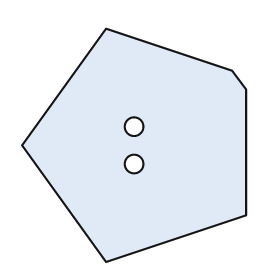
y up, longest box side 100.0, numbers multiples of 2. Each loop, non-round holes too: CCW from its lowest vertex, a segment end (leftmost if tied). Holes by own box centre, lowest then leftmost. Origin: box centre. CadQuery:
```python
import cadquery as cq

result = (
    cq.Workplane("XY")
    .moveTo(-12.0, -50.0)
    .lineTo(48.0, -30.0)
    .lineTo(48.0, 24.0)
    .lineTo(42.0, 32.0)
    .lineTo(-12.0, 50.0)
    .lineTo(-48.0, 0.0)
    .close()
    .moveTo(0.0, -8.0)
    .circle(4.0)
    .moveTo(0.0, 8.0)
    .circle(4.0)
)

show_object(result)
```